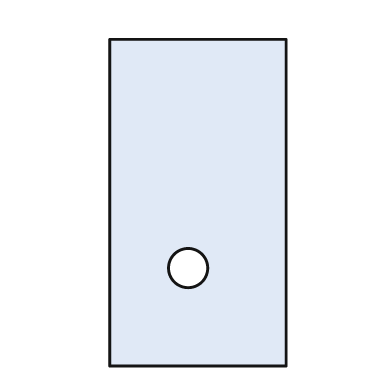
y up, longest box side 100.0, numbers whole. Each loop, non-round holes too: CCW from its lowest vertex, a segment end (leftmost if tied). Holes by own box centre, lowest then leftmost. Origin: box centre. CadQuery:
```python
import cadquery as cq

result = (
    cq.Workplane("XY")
    .moveTo(-27.0, -50.0)
    .lineTo(27.0, -50.0)
    .lineTo(27.0, 50.0)
    .lineTo(-27.0, 50.0)
    .close()
    .moveTo(-3.0, -20.0)
    .circle(6.0)
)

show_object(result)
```